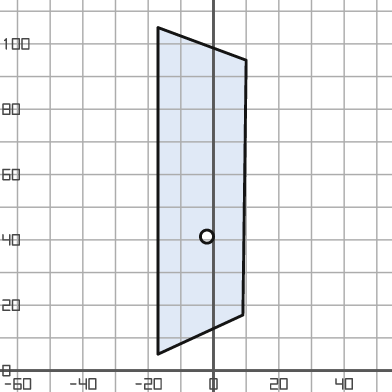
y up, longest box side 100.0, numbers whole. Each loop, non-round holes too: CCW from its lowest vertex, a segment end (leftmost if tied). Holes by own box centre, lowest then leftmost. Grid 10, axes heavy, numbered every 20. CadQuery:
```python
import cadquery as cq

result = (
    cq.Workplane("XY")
    .moveTo(-17.0, 5.0)
    .lineTo(9.0, 17.0)
    .lineTo(10.0, 95.0)
    .lineTo(-17.0, 105.0)
    .close()
    .moveTo(-2.0, 41.0)
    .circle(2.0)
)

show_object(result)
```